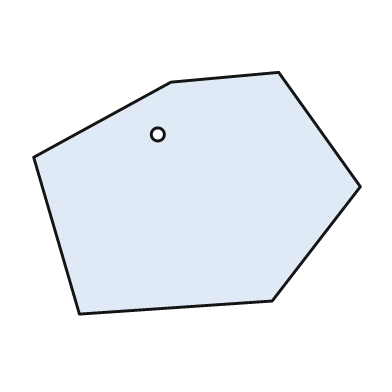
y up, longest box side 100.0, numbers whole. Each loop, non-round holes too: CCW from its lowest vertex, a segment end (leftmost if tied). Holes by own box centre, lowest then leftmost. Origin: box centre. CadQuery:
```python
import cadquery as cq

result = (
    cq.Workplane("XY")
    .moveTo(-36.0, -37.0)
    .lineTo(23.0, -33.0)
    .lineTo(50.0, 2.0)
    .lineTo(25.0, 37.0)
    .lineTo(-8.0, 34.0)
    .lineTo(-50.0, 11.0)
    .close()
    .moveTo(-12.0, 18.0)
    .circle(2.0)
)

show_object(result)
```